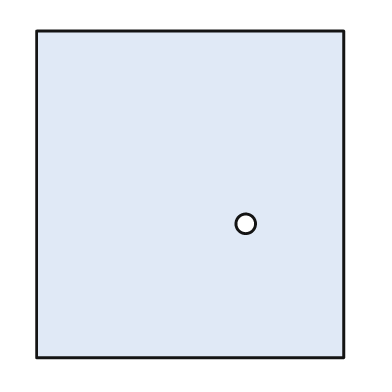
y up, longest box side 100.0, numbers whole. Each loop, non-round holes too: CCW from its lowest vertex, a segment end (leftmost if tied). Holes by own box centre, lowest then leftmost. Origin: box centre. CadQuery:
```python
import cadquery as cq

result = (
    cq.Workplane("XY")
    .moveTo(-47.0, -50.0)
    .lineTo(47.0, -50.0)
    .lineTo(47.0, 50.0)
    .lineTo(-47.0, 50.0)
    .close()
    .moveTo(17.0, -9.0)
    .circle(3.0)
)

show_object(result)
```